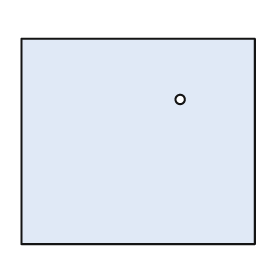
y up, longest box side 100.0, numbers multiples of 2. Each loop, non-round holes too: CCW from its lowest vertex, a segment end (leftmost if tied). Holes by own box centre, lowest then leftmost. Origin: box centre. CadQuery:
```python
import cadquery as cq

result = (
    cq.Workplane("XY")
    .moveTo(-50.0, -44.0)
    .lineTo(50.0, -44.0)
    .lineTo(50.0, 44.0)
    .lineTo(-50.0, 44.0)
    .close()
    .moveTo(18.0, 18.0)
    .circle(2.0)
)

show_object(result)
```